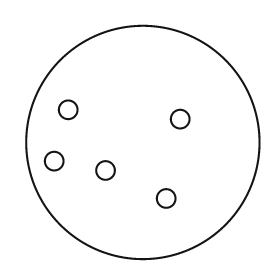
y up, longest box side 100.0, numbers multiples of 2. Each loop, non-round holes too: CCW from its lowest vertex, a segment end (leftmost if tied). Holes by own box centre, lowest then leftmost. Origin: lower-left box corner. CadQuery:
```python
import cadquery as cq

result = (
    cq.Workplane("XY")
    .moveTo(50.0, 50.0)
    .circle(50.0)
    .moveTo(60.0, 26.0)
    .circle(4.0)
    .moveTo(34.0, 38.0)
    .circle(4.0)
    .moveTo(12.0, 42.0)
    .circle(4.0)
    .moveTo(66.0, 60.0)
    .circle(4.0)
    .moveTo(18.0, 64.0)
    .circle(4.0)
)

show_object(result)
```